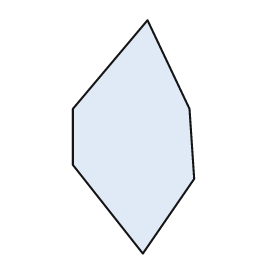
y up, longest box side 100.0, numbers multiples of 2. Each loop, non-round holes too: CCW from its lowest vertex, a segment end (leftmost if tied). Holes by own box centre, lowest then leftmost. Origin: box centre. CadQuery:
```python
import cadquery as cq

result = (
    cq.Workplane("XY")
    .moveTo(4.0, -50.0)
    .lineTo(26.0, -18.0)
    .lineTo(24.0, 12.0)
    .lineTo(6.0, 50.0)
    .lineTo(-26.0, 12.0)
    .lineTo(-26.0, -12.0)
    .close()
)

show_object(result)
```